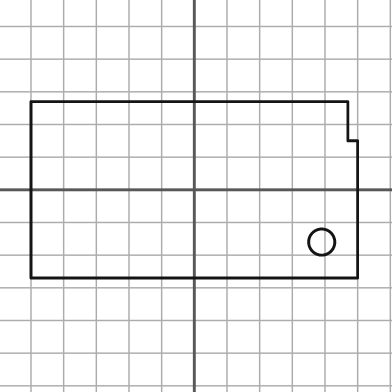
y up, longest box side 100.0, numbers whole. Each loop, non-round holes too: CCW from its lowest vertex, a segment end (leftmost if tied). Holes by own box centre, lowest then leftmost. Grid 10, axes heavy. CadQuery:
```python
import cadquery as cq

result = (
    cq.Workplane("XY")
    .moveTo(-50.0, -27.0)
    .lineTo(50.0, -27.0)
    .lineTo(50.0, 15.0)
    .lineTo(47.0, 15.0)
    .lineTo(47.0, 27.0)
    .lineTo(-50.0, 27.0)
    .close()
    .moveTo(39.0, -16.0)
    .circle(4.0)
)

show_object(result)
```